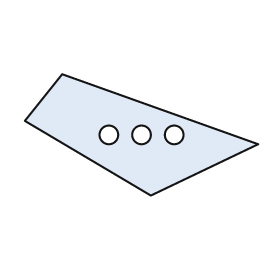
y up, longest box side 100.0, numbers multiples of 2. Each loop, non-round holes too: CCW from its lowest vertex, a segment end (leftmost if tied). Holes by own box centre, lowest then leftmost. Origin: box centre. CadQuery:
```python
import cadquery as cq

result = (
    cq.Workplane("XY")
    .moveTo(4.0, -26.0)
    .lineTo(50.0, -4.0)
    .lineTo(-34.0, 26.0)
    .lineTo(-50.0, 6.0)
    .close()
    .moveTo(-14.0, 0.0)
    .circle(4.0)
    .moveTo(0.0, 0.0)
    .circle(4.0)
    .moveTo(14.0, 0.0)
    .circle(4.0)
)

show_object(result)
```